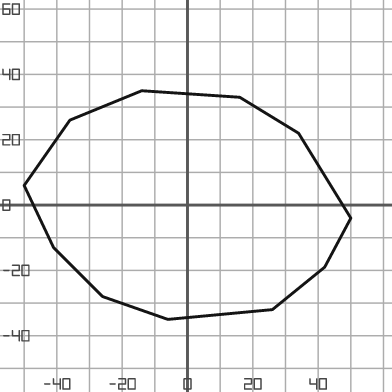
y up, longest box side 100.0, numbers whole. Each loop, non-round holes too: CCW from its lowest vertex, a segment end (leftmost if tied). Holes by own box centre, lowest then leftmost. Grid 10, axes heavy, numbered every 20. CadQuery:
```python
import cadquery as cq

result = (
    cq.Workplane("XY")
    .moveTo(-6.0, -35.0)
    .lineTo(26.0, -32.0)
    .lineTo(42.0, -19.0)
    .lineTo(50.0, -4.0)
    .lineTo(34.0, 22.0)
    .lineTo(16.0, 33.0)
    .lineTo(-14.0, 35.0)
    .lineTo(-36.0, 26.0)
    .lineTo(-50.0, 6.0)
    .lineTo(-41.0, -13.0)
    .lineTo(-26.0, -28.0)
    .close()
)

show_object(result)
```